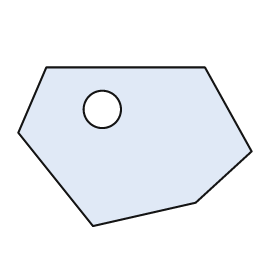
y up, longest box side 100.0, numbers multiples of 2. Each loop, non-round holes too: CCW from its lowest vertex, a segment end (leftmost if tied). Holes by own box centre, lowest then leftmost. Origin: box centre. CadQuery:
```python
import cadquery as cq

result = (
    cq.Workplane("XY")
    .moveTo(-18.0, -34.0)
    .lineTo(26.0, -24.0)
    .lineTo(50.0, -2.0)
    .lineTo(30.0, 34.0)
    .lineTo(-38.0, 34.0)
    .lineTo(-50.0, 6.0)
    .close()
    .moveTo(-14.0, 16.0)
    .circle(8.0)
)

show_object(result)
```